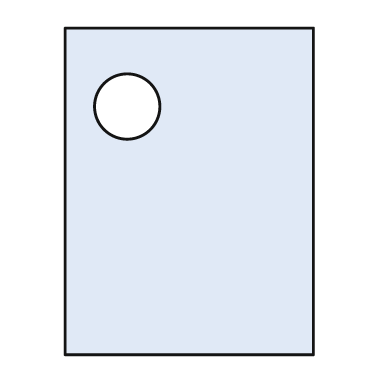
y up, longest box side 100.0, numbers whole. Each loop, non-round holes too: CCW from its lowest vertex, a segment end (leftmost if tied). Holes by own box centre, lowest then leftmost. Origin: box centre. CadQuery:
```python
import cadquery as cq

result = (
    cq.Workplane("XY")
    .moveTo(-38.0, -50.0)
    .lineTo(38.0, -50.0)
    .lineTo(38.0, 50.0)
    .lineTo(-38.0, 50.0)
    .close()
    .moveTo(-19.0, 26.0)
    .circle(10.0)
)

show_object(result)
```